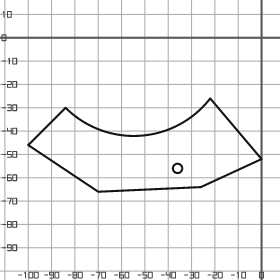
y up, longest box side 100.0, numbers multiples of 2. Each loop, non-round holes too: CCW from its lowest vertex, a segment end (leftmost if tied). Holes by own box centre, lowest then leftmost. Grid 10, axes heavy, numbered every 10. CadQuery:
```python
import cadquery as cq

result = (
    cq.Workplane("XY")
    .moveTo(-70.0, -66.0)
    .lineTo(-26.0, -64.0)
    .lineTo(0.0, -52.0)
    .lineTo(-22.0, -26.0)
    .threePointArc((-52.0, -42.0), (-84.0, -30.0))
    .lineTo(-100.0, -46.0)
    .close()
    .moveTo(-36.0, -56.0)
    .circle(2.0)
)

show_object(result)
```